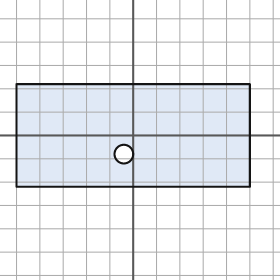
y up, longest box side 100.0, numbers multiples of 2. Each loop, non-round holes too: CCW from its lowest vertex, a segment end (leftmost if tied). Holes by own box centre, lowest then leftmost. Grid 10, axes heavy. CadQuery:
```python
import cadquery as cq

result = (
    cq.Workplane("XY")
    .moveTo(-50.0, -22.0)
    .lineTo(50.0, -22.0)
    .lineTo(50.0, 22.0)
    .lineTo(-50.0, 22.0)
    .close()
    .moveTo(-4.0, -8.0)
    .circle(4.0)
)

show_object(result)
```